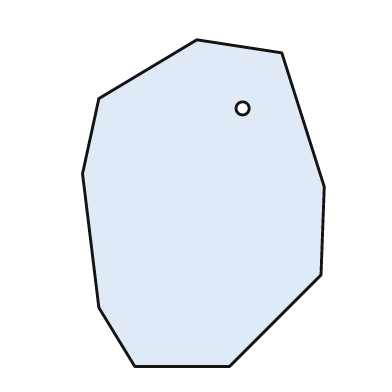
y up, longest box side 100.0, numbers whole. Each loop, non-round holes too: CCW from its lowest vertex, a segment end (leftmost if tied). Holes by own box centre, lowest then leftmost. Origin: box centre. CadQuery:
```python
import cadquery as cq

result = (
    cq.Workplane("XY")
    .moveTo(-21.0, -50.0)
    .lineTo(8.0, -50.0)
    .lineTo(36.0, -22.0)
    .lineTo(37.0, 5.0)
    .lineTo(24.0, 46.0)
    .lineTo(-2.0, 50.0)
    .lineTo(-32.0, 32.0)
    .lineTo(-37.0, 9.0)
    .lineTo(-32.0, -32.0)
    .close()
    .moveTo(12.0, 29.0)
    .circle(2.0)
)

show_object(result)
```